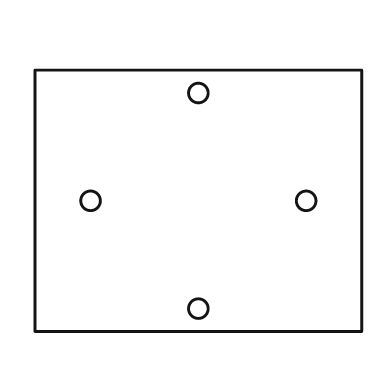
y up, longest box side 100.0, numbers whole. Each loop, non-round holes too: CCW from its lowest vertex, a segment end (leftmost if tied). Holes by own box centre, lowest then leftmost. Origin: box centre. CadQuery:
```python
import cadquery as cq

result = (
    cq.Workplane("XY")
    .moveTo(-50.0, -40.0)
    .lineTo(50.0, -40.0)
    .lineTo(50.0, 40.0)
    .lineTo(-50.0, 40.0)
    .close()
    .moveTo(0.0, -33.0)
    .circle(3.0)
    .moveTo(-33.0, 0.0)
    .circle(3.0)
    .moveTo(33.0, 0.0)
    .circle(3.0)
    .moveTo(0.0, 33.0)
    .circle(3.0)
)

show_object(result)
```